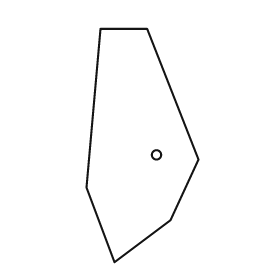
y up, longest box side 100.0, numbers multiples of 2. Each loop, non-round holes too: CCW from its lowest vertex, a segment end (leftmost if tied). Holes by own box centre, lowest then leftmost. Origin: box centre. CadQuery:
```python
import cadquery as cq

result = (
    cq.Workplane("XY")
    .moveTo(-12.0, -50.0)
    .lineTo(12.0, -32.0)
    .lineTo(24.0, -6.0)
    .lineTo(2.0, 50.0)
    .lineTo(-18.0, 50.0)
    .lineTo(-24.0, -18.0)
    .close()
    .moveTo(6.0, -4.0)
    .circle(2.0)
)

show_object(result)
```